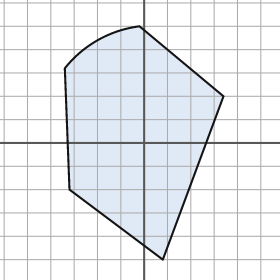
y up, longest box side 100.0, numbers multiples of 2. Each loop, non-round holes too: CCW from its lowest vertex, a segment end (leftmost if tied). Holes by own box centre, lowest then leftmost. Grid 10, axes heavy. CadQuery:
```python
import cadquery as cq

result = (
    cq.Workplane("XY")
    .moveTo(8.0, -50.0)
    .lineTo(34.0, 20.0)
    .lineTo(-2.0, 50.0)
    .threePointArc((-20.0, 44.0), (-34.0, 32.0))
    .lineTo(-32.0, -20.0)
    .close()
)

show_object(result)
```